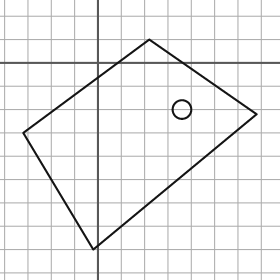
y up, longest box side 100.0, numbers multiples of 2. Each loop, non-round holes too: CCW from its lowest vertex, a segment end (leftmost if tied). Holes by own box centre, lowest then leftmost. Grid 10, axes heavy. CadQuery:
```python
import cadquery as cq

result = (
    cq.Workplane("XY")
    .moveTo(-2.0, -80.0)
    .lineTo(68.0, -22.0)
    .lineTo(22.0, 10.0)
    .lineTo(-32.0, -30.0)
    .close()
    .moveTo(36.0, -20.0)
    .circle(4.0)
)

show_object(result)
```